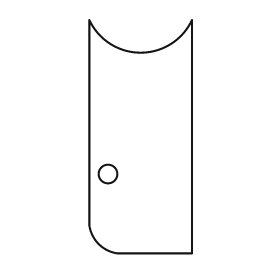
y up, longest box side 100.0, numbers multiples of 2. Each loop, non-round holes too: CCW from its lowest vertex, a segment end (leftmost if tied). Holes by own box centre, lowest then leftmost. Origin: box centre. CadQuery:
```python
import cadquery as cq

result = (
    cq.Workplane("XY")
    .moveTo(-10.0, -50.0)
    .lineTo(22.0, -50.0)
    .lineTo(22.0, 50.0)
    .threePointArc((0.0, 36.0), (-22.0, 50.0))
    .lineTo(-22.0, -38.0)
    .threePointArc((-18.0, -46.0), (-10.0, -50.0))
    .close()
    .moveTo(-14.0, -16.0)
    .circle(4.0)
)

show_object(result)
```